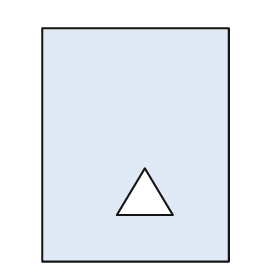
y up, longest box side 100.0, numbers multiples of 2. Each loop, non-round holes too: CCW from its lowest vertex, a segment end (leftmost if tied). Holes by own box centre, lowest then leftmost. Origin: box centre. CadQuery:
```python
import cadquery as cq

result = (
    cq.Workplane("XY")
    .moveTo(-40.0, -50.0)
    .lineTo(40.0, -50.0)
    .lineTo(40.0, 50.0)
    .lineTo(-40.0, 50.0)
    .close()
    .moveTo(-8.0, -30.0)
    .lineTo(16.0, -30.0)
    .lineTo(4.0, -10.0)
    .close()
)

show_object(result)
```